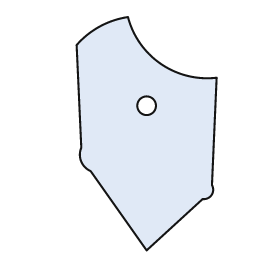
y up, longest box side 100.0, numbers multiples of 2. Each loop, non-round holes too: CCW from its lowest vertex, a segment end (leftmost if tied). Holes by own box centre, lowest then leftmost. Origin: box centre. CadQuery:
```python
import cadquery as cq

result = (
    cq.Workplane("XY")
    .moveTo(0.0, -50.0)
    .lineTo(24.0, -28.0)
    .threePointArc((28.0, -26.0), (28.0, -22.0))
    .lineTo(30.0, 24.0)
    .threePointArc((6.0, 30.0), (-8.0, 50.0))
    .threePointArc((-20.0, 46.0), (-30.0, 38.0))
    .lineTo(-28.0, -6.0)
    .threePointArc((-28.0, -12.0), (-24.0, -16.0))
    .close()
    .moveTo(0.0, 12.0)
    .circle(4.0)
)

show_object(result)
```